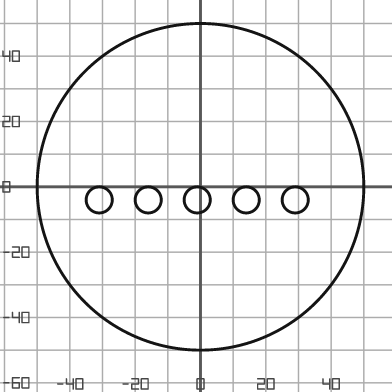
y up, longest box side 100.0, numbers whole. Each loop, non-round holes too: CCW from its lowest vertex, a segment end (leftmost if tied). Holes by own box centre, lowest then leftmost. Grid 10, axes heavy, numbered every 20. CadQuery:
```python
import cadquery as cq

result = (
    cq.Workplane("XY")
    .moveTo(0.0, 0.0)
    .circle(50.0)
    .moveTo(-31.0, -4.0)
    .circle(4.0)
    .moveTo(-16.0, -4.0)
    .circle(4.0)
    .moveTo(-1.0, -4.0)
    .circle(4.0)
    .moveTo(14.0, -4.0)
    .circle(4.0)
    .moveTo(29.0, -4.0)
    .circle(4.0)
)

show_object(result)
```